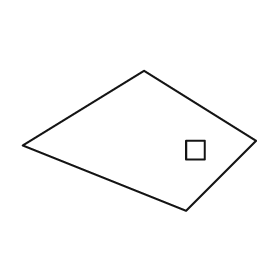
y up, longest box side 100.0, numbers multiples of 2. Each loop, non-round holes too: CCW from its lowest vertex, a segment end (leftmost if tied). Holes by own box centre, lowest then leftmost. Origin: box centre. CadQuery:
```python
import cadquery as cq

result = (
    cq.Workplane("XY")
    .moveTo(20.0, -30.0)
    .lineTo(50.0, 0.0)
    .lineTo(2.0, 30.0)
    .lineTo(-50.0, -2.0)
    .close()
    .moveTo(20.0, -8.0)
    .lineTo(28.0, -8.0)
    .lineTo(28.0, 0.0)
    .lineTo(20.0, 0.0)
    .close()
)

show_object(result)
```